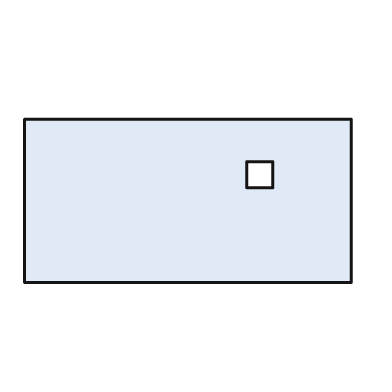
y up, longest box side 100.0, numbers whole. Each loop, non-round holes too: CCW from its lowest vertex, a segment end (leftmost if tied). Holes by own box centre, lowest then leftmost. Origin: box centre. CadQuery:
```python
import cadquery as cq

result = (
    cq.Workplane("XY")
    .moveTo(-50.0, -25.0)
    .lineTo(50.0, -25.0)
    .lineTo(50.0, 25.0)
    .lineTo(-50.0, 25.0)
    .close()
    .moveTo(18.0, 4.0)
    .lineTo(26.0, 4.0)
    .lineTo(26.0, 12.0)
    .lineTo(18.0, 12.0)
    .close()
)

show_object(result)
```